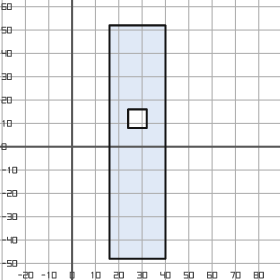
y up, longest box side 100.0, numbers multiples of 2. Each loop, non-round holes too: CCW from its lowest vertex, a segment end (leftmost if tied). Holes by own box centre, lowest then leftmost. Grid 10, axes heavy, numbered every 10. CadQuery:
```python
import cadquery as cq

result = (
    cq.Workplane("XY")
    .moveTo(16.0, -48.0)
    .lineTo(40.0, -48.0)
    .lineTo(40.0, 52.0)
    .lineTo(16.0, 52.0)
    .close()
    .moveTo(24.0, 8.0)
    .lineTo(32.0, 8.0)
    .lineTo(32.0, 16.0)
    .lineTo(24.0, 16.0)
    .close()
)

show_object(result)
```